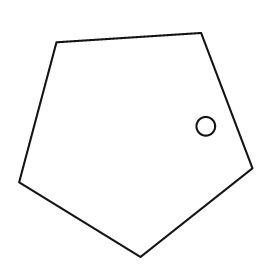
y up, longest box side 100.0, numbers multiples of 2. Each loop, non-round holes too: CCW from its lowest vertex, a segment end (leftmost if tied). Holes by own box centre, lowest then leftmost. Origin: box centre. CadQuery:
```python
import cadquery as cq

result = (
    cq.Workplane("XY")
    .moveTo(2.0, -48.0)
    .lineTo(50.0, -10.0)
    .lineTo(28.0, 48.0)
    .lineTo(-34.0, 44.0)
    .lineTo(-50.0, -16.0)
    .close()
    .moveTo(30.0, 8.0)
    .circle(4.0)
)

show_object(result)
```